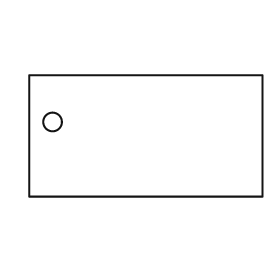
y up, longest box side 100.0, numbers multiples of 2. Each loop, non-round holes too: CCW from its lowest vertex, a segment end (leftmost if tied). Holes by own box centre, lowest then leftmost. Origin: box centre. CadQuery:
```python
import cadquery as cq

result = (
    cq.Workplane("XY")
    .moveTo(-50.0, -26.0)
    .lineTo(50.0, -26.0)
    .lineTo(50.0, 26.0)
    .lineTo(-50.0, 26.0)
    .close()
    .moveTo(-40.0, 6.0)
    .circle(4.0)
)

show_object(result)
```